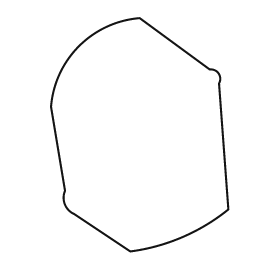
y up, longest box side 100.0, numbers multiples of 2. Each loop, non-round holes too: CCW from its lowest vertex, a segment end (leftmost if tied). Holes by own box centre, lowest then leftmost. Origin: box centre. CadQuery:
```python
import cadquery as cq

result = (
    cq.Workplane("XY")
    .moveTo(-4.0, -50.0)
    .threePointArc((18.0, -44.0), (38.0, -32.0))
    .lineTo(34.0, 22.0)
    .threePointArc((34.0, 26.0), (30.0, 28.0))
    .lineTo(0.0, 50.0)
    .threePointArc((-26.0, 38.0), (-38.0, 12.0))
    .lineTo(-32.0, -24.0)
    .threePointArc((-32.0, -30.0), (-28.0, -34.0))
    .close()
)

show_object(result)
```